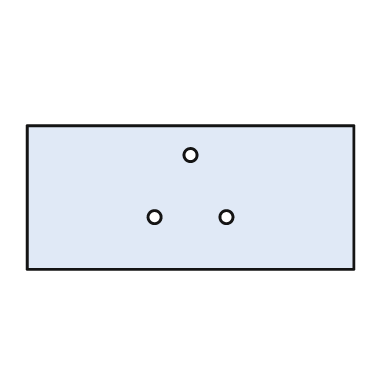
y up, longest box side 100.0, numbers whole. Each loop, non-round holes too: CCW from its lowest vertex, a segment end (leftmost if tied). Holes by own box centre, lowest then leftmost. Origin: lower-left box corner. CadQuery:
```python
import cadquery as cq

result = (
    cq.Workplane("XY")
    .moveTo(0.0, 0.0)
    .lineTo(100.0, 0.0)
    .lineTo(100.0, 44.0)
    .lineTo(0.0, 44.0)
    .close()
    .moveTo(39.0, 16.0)
    .circle(2.0)
    .moveTo(61.0, 16.0)
    .circle(2.0)
    .moveTo(50.0, 35.0)
    .circle(2.0)
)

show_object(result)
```